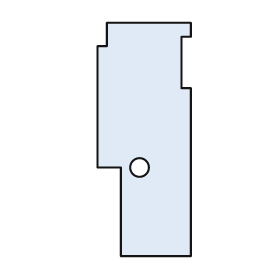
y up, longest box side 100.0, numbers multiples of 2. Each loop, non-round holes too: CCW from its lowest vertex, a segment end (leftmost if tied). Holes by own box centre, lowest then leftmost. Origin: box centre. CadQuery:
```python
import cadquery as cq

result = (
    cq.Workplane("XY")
    .moveTo(-10.0, -50.0)
    .lineTo(20.0, -50.0)
    .lineTo(20.0, 22.0)
    .lineTo(16.0, 22.0)
    .lineTo(16.0, 44.0)
    .lineTo(20.0, 44.0)
    .lineTo(20.0, 50.0)
    .lineTo(-16.0, 50.0)
    .lineTo(-16.0, 40.0)
    .lineTo(-20.0, 40.0)
    .lineTo(-20.0, -12.0)
    .lineTo(-10.0, -12.0)
    .close()
    .moveTo(-2.0, -12.0)
    .circle(4.0)
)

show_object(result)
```